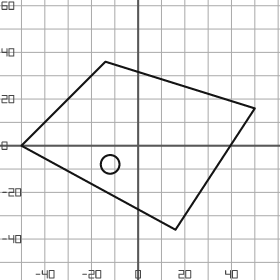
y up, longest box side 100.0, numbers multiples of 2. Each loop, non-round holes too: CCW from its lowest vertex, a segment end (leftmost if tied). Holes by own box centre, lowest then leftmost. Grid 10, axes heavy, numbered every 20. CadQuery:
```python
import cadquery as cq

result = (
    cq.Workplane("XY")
    .moveTo(16.0, -36.0)
    .lineTo(50.0, 16.0)
    .lineTo(-14.0, 36.0)
    .lineTo(-50.0, 0.0)
    .close()
    .moveTo(-12.0, -8.0)
    .circle(4.0)
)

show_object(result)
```